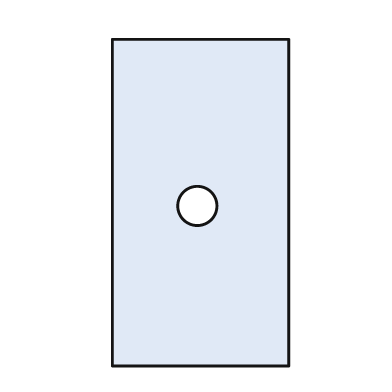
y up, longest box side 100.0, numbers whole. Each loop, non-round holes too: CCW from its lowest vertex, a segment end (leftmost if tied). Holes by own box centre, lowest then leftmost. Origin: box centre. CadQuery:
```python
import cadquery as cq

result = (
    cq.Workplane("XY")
    .moveTo(-27.0, -50.0)
    .lineTo(27.0, -50.0)
    .lineTo(27.0, 50.0)
    .lineTo(-27.0, 50.0)
    .close()
    .moveTo(-1.0, -1.0)
    .circle(6.0)
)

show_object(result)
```